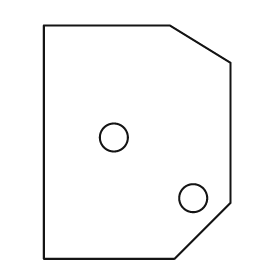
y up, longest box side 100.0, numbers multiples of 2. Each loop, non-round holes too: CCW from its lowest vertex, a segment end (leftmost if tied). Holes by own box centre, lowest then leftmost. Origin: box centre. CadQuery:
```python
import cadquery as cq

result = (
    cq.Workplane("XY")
    .moveTo(-40.0, -50.0)
    .lineTo(16.0, -50.0)
    .lineTo(40.0, -26.0)
    .lineTo(40.0, 34.0)
    .lineTo(14.0, 50.0)
    .lineTo(-40.0, 50.0)
    .close()
    .moveTo(24.0, -24.0)
    .circle(6.0)
    .moveTo(-10.0, 2.0)
    .circle(6.0)
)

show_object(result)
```